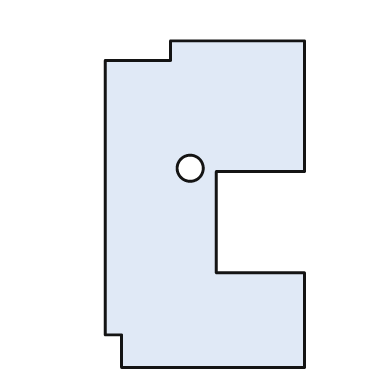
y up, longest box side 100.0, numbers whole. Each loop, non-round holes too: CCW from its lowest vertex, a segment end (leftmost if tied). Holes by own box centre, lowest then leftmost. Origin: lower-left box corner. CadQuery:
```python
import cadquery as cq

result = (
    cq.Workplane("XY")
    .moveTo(5.0, 0.0)
    .lineTo(61.0, 0.0)
    .lineTo(61.0, 29.0)
    .lineTo(34.0, 29.0)
    .lineTo(34.0, 60.0)
    .lineTo(61.0, 60.0)
    .lineTo(61.0, 100.0)
    .lineTo(20.0, 100.0)
    .lineTo(20.0, 94.0)
    .lineTo(0.0, 94.0)
    .lineTo(0.0, 10.0)
    .lineTo(5.0, 10.0)
    .close()
    .moveTo(26.0, 61.0)
    .circle(4.0)
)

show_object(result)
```